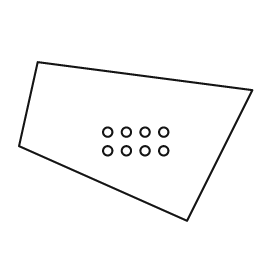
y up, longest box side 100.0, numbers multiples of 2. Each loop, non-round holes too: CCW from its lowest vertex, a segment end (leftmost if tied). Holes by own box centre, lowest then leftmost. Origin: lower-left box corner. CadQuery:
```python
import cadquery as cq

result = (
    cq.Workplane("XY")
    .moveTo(72.0, 0.0)
    .lineTo(100.0, 56.0)
    .lineTo(8.0, 68.0)
    .lineTo(0.0, 32.0)
    .close()
    .moveTo(38.0, 30.0)
    .circle(2.0)
    .moveTo(46.0, 30.0)
    .circle(2.0)
    .moveTo(54.0, 30.0)
    .circle(2.0)
    .moveTo(62.0, 30.0)
    .circle(2.0)
    .moveTo(38.0, 38.0)
    .circle(2.0)
    .moveTo(46.0, 38.0)
    .circle(2.0)
    .moveTo(54.0, 38.0)
    .circle(2.0)
    .moveTo(62.0, 38.0)
    .circle(2.0)
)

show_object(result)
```